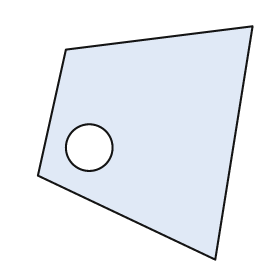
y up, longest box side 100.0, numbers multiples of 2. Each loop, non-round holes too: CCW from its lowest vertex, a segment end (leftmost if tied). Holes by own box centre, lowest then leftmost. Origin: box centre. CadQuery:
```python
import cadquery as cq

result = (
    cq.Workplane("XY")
    .moveTo(30.0, -50.0)
    .lineTo(46.0, 50.0)
    .lineTo(-34.0, 40.0)
    .lineTo(-46.0, -14.0)
    .close()
    .moveTo(-24.0, -2.0)
    .circle(10.0)
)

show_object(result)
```